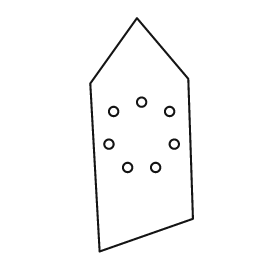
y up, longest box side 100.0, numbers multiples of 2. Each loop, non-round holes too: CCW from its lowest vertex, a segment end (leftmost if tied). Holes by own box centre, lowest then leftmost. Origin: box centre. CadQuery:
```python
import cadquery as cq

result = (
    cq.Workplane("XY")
    .moveTo(-18.0, -50.0)
    .lineTo(22.0, -36.0)
    .lineTo(20.0, 24.0)
    .lineTo(-2.0, 50.0)
    .lineTo(-22.0, 22.0)
    .close()
    .moveTo(-6.0, -14.0)
    .circle(2.0)
    .moveTo(6.0, -14.0)
    .circle(2.0)
    .moveTo(-14.0, -4.0)
    .circle(2.0)
    .moveTo(14.0, -4.0)
    .circle(2.0)
    .moveTo(-12.0, 10.0)
    .circle(2.0)
    .moveTo(12.0, 10.0)
    .circle(2.0)
    .moveTo(0.0, 14.0)
    .circle(2.0)
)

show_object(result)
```